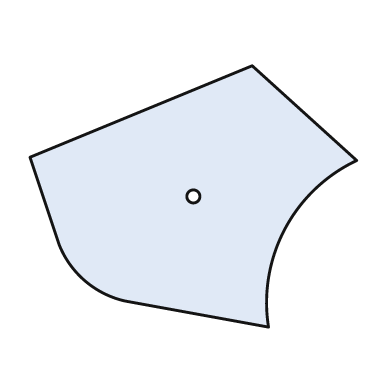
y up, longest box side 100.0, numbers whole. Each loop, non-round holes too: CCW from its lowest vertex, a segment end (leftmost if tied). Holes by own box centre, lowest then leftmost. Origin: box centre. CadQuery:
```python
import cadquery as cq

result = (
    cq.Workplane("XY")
    .moveTo(23.0, -40.0)
    .threePointArc((28.0, -10.0), (50.0, 11.0))
    .lineTo(18.0, 40.0)
    .lineTo(-50.0, 12.0)
    .lineTo(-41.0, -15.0)
    .threePointArc((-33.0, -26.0), (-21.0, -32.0))
    .close()
    .moveTo(0.0, 0.0)
    .circle(2.0)
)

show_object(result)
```